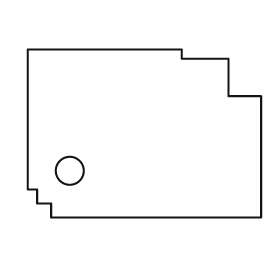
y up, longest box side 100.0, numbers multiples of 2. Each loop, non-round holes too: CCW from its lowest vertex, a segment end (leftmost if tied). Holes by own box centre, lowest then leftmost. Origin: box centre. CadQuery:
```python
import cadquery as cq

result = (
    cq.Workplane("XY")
    .moveTo(-40.0, -36.0)
    .lineTo(50.0, -36.0)
    .lineTo(50.0, 16.0)
    .lineTo(36.0, 16.0)
    .lineTo(36.0, 32.0)
    .lineTo(16.0, 32.0)
    .lineTo(16.0, 36.0)
    .lineTo(-50.0, 36.0)
    .lineTo(-50.0, -24.0)
    .lineTo(-46.0, -24.0)
    .lineTo(-46.0, -30.0)
    .lineTo(-40.0, -30.0)
    .close()
    .moveTo(-32.0, -16.0)
    .circle(6.0)
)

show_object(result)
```